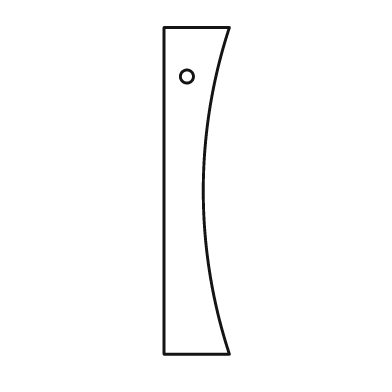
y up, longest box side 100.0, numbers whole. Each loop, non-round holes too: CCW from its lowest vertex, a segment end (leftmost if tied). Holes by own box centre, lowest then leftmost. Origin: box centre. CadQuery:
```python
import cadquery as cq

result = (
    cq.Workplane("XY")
    .moveTo(-10.0, -50.0)
    .lineTo(10.0, -50.0)
    .threePointArc((2.0, 0.0), (10.0, 50.0))
    .lineTo(-10.0, 50.0)
    .close()
    .moveTo(-3.0, 35.0)
    .circle(2.0)
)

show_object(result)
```